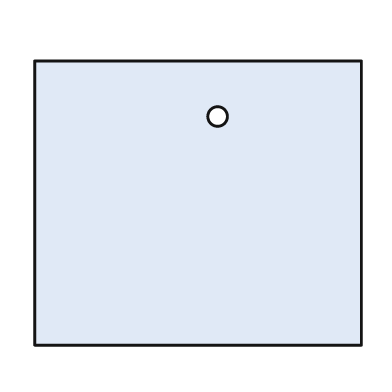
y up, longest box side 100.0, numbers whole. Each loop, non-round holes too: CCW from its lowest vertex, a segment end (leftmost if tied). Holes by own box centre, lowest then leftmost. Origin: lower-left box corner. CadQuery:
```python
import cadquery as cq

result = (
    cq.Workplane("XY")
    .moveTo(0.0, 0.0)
    .lineTo(100.0, 0.0)
    .lineTo(100.0, 87.0)
    .lineTo(0.0, 87.0)
    .close()
    .moveTo(56.0, 70.0)
    .circle(3.0)
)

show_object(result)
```